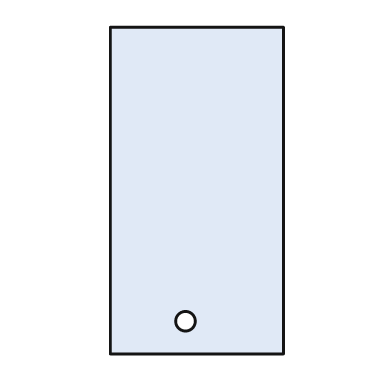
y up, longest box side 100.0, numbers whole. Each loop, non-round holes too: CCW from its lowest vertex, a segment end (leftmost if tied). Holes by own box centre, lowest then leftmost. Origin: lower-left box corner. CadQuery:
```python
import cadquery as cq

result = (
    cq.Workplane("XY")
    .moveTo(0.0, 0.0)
    .lineTo(53.0, 0.0)
    .lineTo(53.0, 100.0)
    .lineTo(0.0, 100.0)
    .close()
    .moveTo(23.0, 10.0)
    .circle(3.0)
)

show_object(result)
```